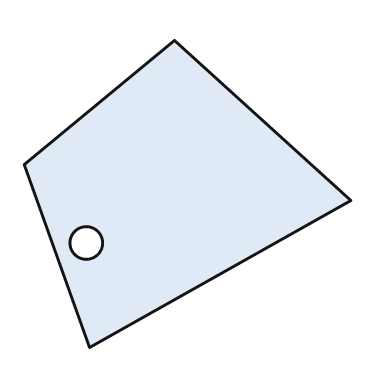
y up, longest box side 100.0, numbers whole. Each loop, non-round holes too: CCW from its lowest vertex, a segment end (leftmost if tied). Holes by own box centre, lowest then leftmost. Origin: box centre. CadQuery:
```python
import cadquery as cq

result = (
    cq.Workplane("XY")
    .moveTo(-30.0, -47.0)
    .lineTo(50.0, -2.0)
    .lineTo(-4.0, 47.0)
    .lineTo(-50.0, 9.0)
    .close()
    .moveTo(-31.0, -15.0)
    .circle(5.0)
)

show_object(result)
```